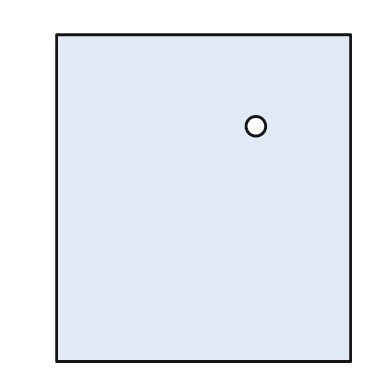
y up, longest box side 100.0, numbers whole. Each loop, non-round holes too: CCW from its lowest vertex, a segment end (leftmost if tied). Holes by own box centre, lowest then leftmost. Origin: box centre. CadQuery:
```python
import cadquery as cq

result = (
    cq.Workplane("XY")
    .moveTo(-45.0, -50.0)
    .lineTo(45.0, -50.0)
    .lineTo(45.0, 50.0)
    .lineTo(-45.0, 50.0)
    .close()
    .moveTo(16.0, 22.0)
    .circle(3.0)
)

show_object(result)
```